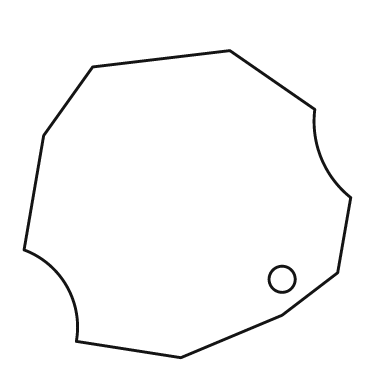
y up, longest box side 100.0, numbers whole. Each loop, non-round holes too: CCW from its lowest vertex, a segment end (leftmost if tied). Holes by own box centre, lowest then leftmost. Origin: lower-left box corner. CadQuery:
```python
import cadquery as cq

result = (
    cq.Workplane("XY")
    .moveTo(48.0, 0.0)
    .lineTo(79.0, 13.0)
    .lineTo(96.0, 26.0)
    .lineTo(100.0, 49.0)
    .threePointArc((91.0, 61.0), (89.0, 76.0))
    .lineTo(63.0, 94.0)
    .lineTo(21.0, 89.0)
    .lineTo(6.0, 68.0)
    .lineTo(0.0, 33.0)
    .threePointArc((13.0, 22.0), (16.0, 5.0))
    .close()
    .moveTo(79.0, 24.0)
    .circle(4.0)
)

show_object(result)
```